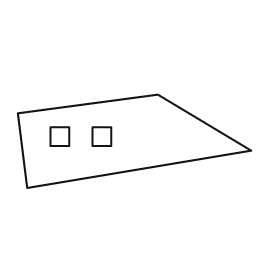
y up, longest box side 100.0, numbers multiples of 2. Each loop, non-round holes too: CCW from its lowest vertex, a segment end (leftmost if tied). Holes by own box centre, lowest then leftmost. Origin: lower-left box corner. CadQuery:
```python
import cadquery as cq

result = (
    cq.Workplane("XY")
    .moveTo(4.0, 0.0)
    .lineTo(100.0, 16.0)
    .lineTo(60.0, 40.0)
    .lineTo(0.0, 32.0)
    .close()
    .moveTo(14.0, 18.0)
    .lineTo(22.0, 18.0)
    .lineTo(22.0, 26.0)
    .lineTo(14.0, 26.0)
    .close()
    .moveTo(32.0, 18.0)
    .lineTo(40.0, 18.0)
    .lineTo(40.0, 26.0)
    .lineTo(32.0, 26.0)
    .close()
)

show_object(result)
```